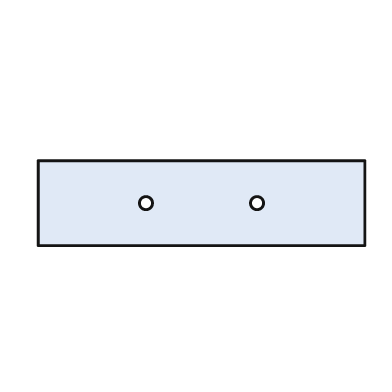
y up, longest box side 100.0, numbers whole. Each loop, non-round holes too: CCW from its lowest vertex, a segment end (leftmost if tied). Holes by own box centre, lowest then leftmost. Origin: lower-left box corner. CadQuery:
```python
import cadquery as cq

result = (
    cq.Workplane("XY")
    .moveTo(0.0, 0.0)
    .lineTo(100.0, 0.0)
    .lineTo(100.0, 26.0)
    .lineTo(0.0, 26.0)
    .close()
    .moveTo(33.0, 13.0)
    .circle(2.0)
    .moveTo(67.0, 13.0)
    .circle(2.0)
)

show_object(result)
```